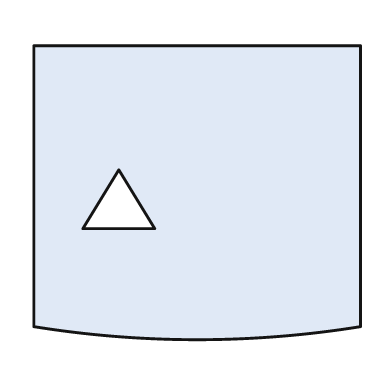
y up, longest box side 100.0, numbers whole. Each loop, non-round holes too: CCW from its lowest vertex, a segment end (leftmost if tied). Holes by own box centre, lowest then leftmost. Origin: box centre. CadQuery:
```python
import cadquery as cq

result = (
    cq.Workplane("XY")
    .moveTo(-50.0, -41.0)
    .threePointArc((0.0, -45.0), (50.0, -41.0))
    .lineTo(50.0, 45.0)
    .lineTo(-50.0, 45.0)
    .close()
    .moveTo(-35.0, -11.0)
    .lineTo(-13.0, -11.0)
    .lineTo(-24.0, 7.0)
    .close()
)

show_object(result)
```